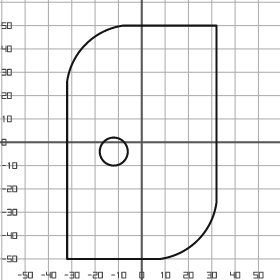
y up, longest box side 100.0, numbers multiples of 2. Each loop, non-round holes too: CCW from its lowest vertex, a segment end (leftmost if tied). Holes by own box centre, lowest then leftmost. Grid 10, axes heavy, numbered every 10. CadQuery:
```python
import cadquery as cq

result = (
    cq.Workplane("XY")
    .moveTo(-32.0, -50.0)
    .lineTo(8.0, -50.0)
    .threePointArc((24.0, -42.0), (32.0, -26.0))
    .lineTo(32.0, 50.0)
    .lineTo(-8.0, 50.0)
    .threePointArc((-24.0, 42.0), (-32.0, 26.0))
    .close()
    .moveTo(-12.0, -4.0)
    .circle(6.0)
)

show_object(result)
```